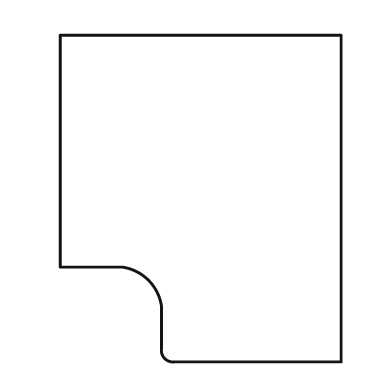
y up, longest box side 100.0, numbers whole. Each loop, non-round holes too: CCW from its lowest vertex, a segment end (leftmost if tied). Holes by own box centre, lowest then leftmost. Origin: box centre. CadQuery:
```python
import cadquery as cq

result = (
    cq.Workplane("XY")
    .moveTo(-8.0, -50.0)
    .lineTo(43.0, -50.0)
    .lineTo(43.0, 50.0)
    .lineTo(-43.0, 50.0)
    .lineTo(-43.0, -21.0)
    .lineTo(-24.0, -21.0)
    .threePointArc((-16.0, -25.0), (-12.0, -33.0))
    .lineTo(-12.0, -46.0)
    .threePointArc((-11.0, -49.0), (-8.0, -50.0))
    .close()
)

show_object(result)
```